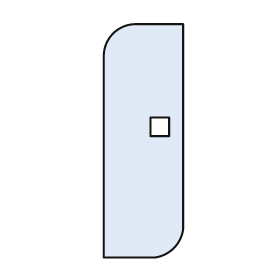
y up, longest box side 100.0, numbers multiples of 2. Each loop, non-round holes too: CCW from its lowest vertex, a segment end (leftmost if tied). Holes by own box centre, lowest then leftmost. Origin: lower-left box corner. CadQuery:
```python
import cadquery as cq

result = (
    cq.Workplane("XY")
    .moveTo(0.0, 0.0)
    .lineTo(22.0, 0.0)
    .threePointArc((30.0, 4.0), (34.0, 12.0))
    .lineTo(34.0, 100.0)
    .lineTo(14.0, 100.0)
    .threePointArc((4.0, 96.0), (0.0, 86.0))
    .close()
    .moveTo(20.0, 52.0)
    .lineTo(28.0, 52.0)
    .lineTo(28.0, 60.0)
    .lineTo(20.0, 60.0)
    .close()
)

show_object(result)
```